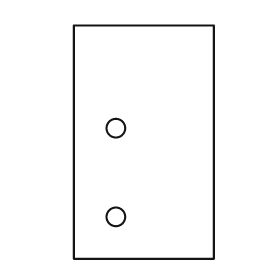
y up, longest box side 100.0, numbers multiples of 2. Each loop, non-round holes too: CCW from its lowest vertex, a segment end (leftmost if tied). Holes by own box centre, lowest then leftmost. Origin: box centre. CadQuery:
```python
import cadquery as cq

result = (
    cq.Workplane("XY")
    .moveTo(-30.0, -50.0)
    .lineTo(30.0, -50.0)
    .lineTo(30.0, 50.0)
    .lineTo(-30.0, 50.0)
    .close()
    .moveTo(-12.0, -32.0)
    .circle(4.0)
    .moveTo(-12.0, 6.0)
    .circle(4.0)
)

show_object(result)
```